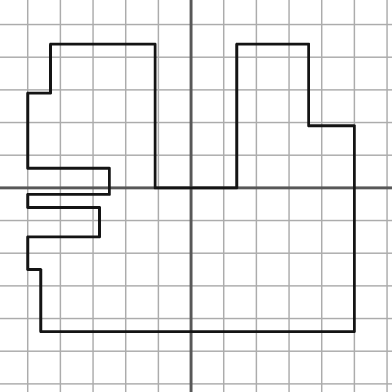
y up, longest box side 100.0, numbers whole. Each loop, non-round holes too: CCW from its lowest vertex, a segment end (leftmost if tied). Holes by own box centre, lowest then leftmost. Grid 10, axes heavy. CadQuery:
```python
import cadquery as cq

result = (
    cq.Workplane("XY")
    .moveTo(-46.0, -44.0)
    .lineTo(50.0, -44.0)
    .lineTo(50.0, 19.0)
    .lineTo(36.0, 19.0)
    .lineTo(36.0, 44.0)
    .lineTo(14.0, 44.0)
    .lineTo(14.0, 0.0)
    .lineTo(-11.0, 0.0)
    .lineTo(-11.0, 44.0)
    .lineTo(-43.0, 44.0)
    .lineTo(-43.0, 29.0)
    .lineTo(-50.0, 29.0)
    .lineTo(-50.0, 6.0)
    .lineTo(-25.0, 6.0)
    .lineTo(-25.0, -2.0)
    .lineTo(-50.0, -2.0)
    .lineTo(-50.0, -6.0)
    .lineTo(-28.0, -6.0)
    .lineTo(-28.0, -15.0)
    .lineTo(-50.0, -15.0)
    .lineTo(-50.0, -25.0)
    .lineTo(-46.0, -25.0)
    .close()
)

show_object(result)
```